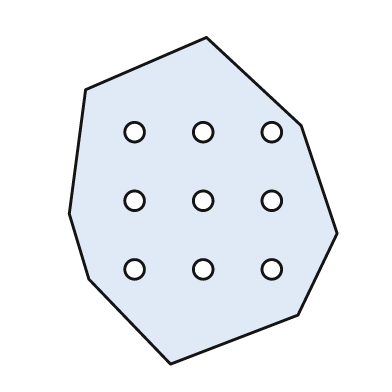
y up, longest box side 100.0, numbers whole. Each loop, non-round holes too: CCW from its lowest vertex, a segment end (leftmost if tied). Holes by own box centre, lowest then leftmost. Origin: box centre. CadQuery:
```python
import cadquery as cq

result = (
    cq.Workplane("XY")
    .moveTo(-10.0, -50.0)
    .lineTo(29.0, -35.0)
    .lineTo(41.0, -10.0)
    .lineTo(30.0, 23.0)
    .lineTo(1.0, 50.0)
    .lineTo(-36.0, 34.0)
    .lineTo(-41.0, -4.0)
    .lineTo(-35.0, -24.0)
    .close()
    .moveTo(-21.0, -21.0)
    .circle(3.0)
    .moveTo(0.0, -21.0)
    .circle(3.0)
    .moveTo(21.0, -21.0)
    .circle(3.0)
    .moveTo(-21.0, 0.0)
    .circle(3.0)
    .moveTo(0.0, 0.0)
    .circle(3.0)
    .moveTo(21.0, 0.0)
    .circle(3.0)
    .moveTo(-21.0, 21.0)
    .circle(3.0)
    .moveTo(0.0, 21.0)
    .circle(3.0)
    .moveTo(21.0, 21.0)
    .circle(3.0)
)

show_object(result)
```